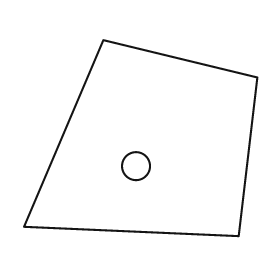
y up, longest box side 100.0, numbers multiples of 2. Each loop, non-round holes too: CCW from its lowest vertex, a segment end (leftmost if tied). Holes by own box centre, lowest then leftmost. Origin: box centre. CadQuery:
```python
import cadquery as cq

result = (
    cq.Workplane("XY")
    .moveTo(42.0, -42.0)
    .lineTo(50.0, 26.0)
    .lineTo(-16.0, 42.0)
    .lineTo(-50.0, -38.0)
    .close()
    .moveTo(-2.0, -12.0)
    .circle(6.0)
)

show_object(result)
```